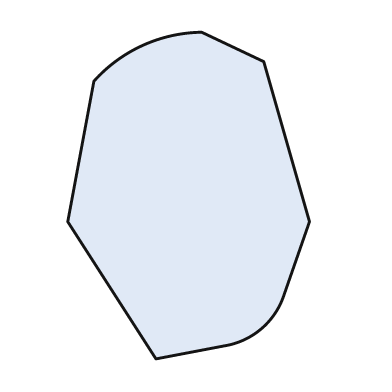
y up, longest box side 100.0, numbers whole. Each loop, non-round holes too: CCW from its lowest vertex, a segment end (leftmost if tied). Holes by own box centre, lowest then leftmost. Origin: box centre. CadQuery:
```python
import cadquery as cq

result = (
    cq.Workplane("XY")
    .moveTo(-10.0, -50.0)
    .lineTo(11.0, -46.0)
    .threePointArc((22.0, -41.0), (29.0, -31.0))
    .lineTo(37.0, -8.0)
    .lineTo(23.0, 41.0)
    .lineTo(4.0, 50.0)
    .threePointArc((-14.0, 46.0), (-29.0, 35.0))
    .lineTo(-37.0, -8.0)
    .close()
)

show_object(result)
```